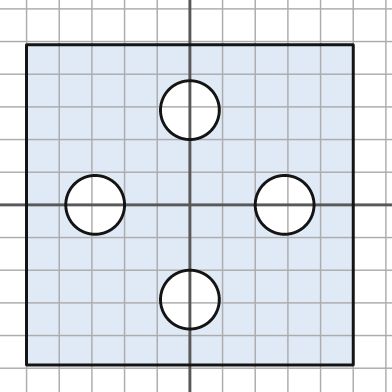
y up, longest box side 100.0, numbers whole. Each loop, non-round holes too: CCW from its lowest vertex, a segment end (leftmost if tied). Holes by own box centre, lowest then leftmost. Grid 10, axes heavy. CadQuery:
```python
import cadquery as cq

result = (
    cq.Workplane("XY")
    .moveTo(-50.0, -49.0)
    .lineTo(50.0, -49.0)
    .lineTo(50.0, 49.0)
    .lineTo(-50.0, 49.0)
    .close()
    .moveTo(0.0, -29.0)
    .circle(9.0)
    .moveTo(-29.0, 0.0)
    .circle(9.0)
    .moveTo(29.0, 0.0)
    .circle(9.0)
    .moveTo(0.0, 29.0)
    .circle(9.0)
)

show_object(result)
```